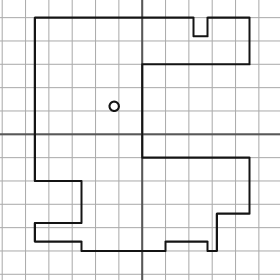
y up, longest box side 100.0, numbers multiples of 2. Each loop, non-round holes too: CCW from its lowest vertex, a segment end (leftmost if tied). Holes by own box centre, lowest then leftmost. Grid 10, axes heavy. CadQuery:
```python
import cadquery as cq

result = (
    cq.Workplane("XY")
    .moveTo(-26.0, -50.0)
    .lineTo(10.0, -50.0)
    .lineTo(10.0, -46.0)
    .lineTo(28.0, -46.0)
    .lineTo(28.0, -50.0)
    .lineTo(32.0, -50.0)
    .lineTo(32.0, -34.0)
    .lineTo(46.0, -34.0)
    .lineTo(46.0, -10.0)
    .lineTo(0.0, -10.0)
    .lineTo(0.0, 30.0)
    .lineTo(46.0, 30.0)
    .lineTo(46.0, 50.0)
    .lineTo(28.0, 50.0)
    .lineTo(28.0, 42.0)
    .lineTo(22.0, 42.0)
    .lineTo(22.0, 50.0)
    .lineTo(-46.0, 50.0)
    .lineTo(-46.0, -20.0)
    .lineTo(-26.0, -20.0)
    .lineTo(-26.0, -38.0)
    .lineTo(-46.0, -38.0)
    .lineTo(-46.0, -46.0)
    .lineTo(-26.0, -46.0)
    .close()
    .moveTo(-12.0, 12.0)
    .circle(2.0)
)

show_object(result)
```